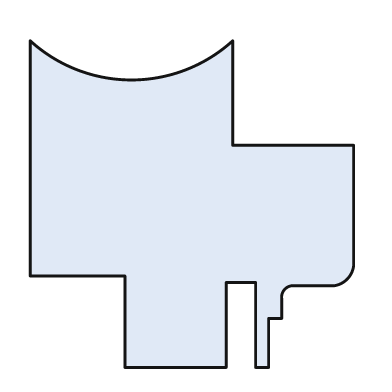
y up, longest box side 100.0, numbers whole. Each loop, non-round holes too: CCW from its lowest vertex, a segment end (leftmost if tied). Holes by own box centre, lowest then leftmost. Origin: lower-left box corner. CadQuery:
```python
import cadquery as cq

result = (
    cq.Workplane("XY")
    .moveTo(29.0, 0.0)
    .lineTo(60.0, 0.0)
    .lineTo(60.0, 26.0)
    .lineTo(69.0, 26.0)
    .lineTo(69.0, 0.0)
    .lineTo(73.0, 0.0)
    .lineTo(73.0, 15.0)
    .lineTo(77.0, 15.0)
    .lineTo(77.0, 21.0)
    .threePointArc((78.0, 24.0), (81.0, 25.0))
    .lineTo(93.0, 25.0)
    .threePointArc((97.0, 27.0), (99.0, 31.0))
    .lineTo(99.0, 68.0)
    .lineTo(62.0, 68.0)
    .lineTo(62.0, 100.0)
    .threePointArc((31.0, 88.0), (0.0, 100.0))
    .lineTo(0.0, 28.0)
    .lineTo(29.0, 28.0)
    .close()
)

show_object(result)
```